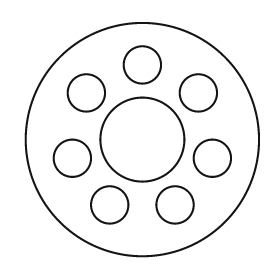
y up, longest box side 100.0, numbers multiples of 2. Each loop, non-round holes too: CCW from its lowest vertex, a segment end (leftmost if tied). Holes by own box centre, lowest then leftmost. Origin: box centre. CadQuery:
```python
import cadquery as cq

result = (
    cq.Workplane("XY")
    .moveTo(0.0, 0.0)
    .circle(50.0)
    .moveTo(-14.0, -28.0)
    .circle(8.0)
    .moveTo(14.0, -28.0)
    .circle(8.0)
    .moveTo(-30.0, -8.0)
    .circle(8.0)
    .moveTo(30.0, -8.0)
    .circle(8.0)
    .moveTo(0.0, 0.0)
    .circle(18.0)
    .moveTo(-24.0, 20.0)
    .circle(8.0)
    .moveTo(24.0, 20.0)
    .circle(8.0)
    .moveTo(0.0, 32.0)
    .circle(8.0)
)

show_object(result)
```